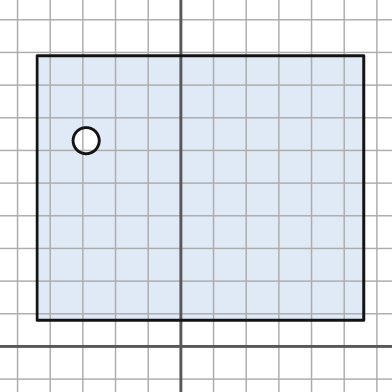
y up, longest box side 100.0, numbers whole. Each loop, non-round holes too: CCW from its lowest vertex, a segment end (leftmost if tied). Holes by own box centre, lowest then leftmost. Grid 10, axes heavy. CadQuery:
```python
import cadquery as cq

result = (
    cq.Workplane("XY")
    .moveTo(-44.0, 8.0)
    .lineTo(56.0, 8.0)
    .lineTo(56.0, 89.0)
    .lineTo(-44.0, 89.0)
    .close()
    .moveTo(-29.0, 63.0)
    .circle(4.0)
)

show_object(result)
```